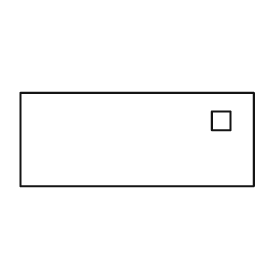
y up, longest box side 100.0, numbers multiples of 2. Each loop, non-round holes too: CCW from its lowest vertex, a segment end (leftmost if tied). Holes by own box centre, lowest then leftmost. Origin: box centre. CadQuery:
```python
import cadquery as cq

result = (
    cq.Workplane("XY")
    .moveTo(-50.0, -20.0)
    .lineTo(50.0, -20.0)
    .lineTo(50.0, 20.0)
    .lineTo(-50.0, 20.0)
    .close()
    .moveTo(32.0, 4.0)
    .lineTo(40.0, 4.0)
    .lineTo(40.0, 12.0)
    .lineTo(32.0, 12.0)
    .close()
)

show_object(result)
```